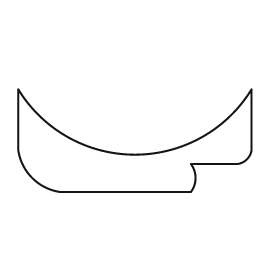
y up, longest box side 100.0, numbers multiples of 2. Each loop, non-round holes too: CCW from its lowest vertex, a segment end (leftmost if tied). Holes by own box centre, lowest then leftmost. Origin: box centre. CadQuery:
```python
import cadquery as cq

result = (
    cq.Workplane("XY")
    .moveTo(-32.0, -22.0)
    .lineTo(24.0, -22.0)
    .threePointArc((26.0, -16.0), (24.0, -10.0))
    .lineTo(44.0, -10.0)
    .threePointArc((48.0, -8.0), (50.0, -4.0))
    .lineTo(50.0, 22.0)
    .threePointArc((0.0, -6.0), (-50.0, 22.0))
    .lineTo(-50.0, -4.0)
    .threePointArc((-44.0, -16.0), (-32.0, -22.0))
    .close()
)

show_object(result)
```